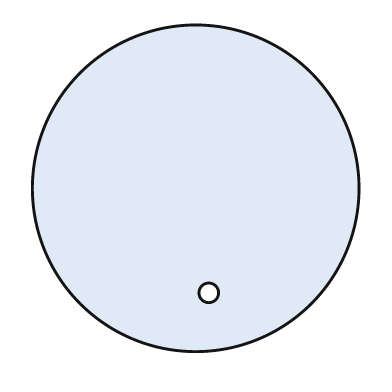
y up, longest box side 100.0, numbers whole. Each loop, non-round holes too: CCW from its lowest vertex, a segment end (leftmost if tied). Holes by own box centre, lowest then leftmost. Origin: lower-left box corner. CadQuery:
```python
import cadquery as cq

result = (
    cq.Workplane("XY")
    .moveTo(50.0, 50.0)
    .circle(50.0)
    .moveTo(54.0, 18.0)
    .circle(3.0)
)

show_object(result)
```